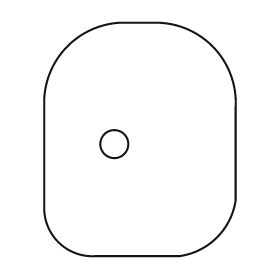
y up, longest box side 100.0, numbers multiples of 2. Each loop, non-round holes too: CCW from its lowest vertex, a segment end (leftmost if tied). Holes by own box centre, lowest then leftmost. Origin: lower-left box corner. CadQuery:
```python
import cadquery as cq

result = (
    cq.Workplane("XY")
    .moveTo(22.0, 0.0)
    .lineTo(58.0, 0.0)
    .threePointArc((74.0, 8.0), (82.0, 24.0))
    .lineTo(82.0, 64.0)
    .threePointArc((72.0, 90.0), (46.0, 100.0))
    .lineTo(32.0, 100.0)
    .threePointArc((10.0, 90.0), (0.0, 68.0))
    .lineTo(0.0, 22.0)
    .threePointArc((6.0, 6.0), (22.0, 0.0))
    .close()
    .moveTo(30.0, 48.0)
    .circle(6.0)
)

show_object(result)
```